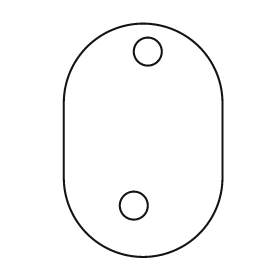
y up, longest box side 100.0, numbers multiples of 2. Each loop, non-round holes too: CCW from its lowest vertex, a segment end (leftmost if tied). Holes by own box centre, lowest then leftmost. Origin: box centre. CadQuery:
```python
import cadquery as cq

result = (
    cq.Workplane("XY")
    .moveTo(-34.0, -16.0)
    .threePointArc((0.0, -50.0), (34.0, -16.0))
    .lineTo(34.0, 16.0)
    .threePointArc((0.0, 50.0), (-34.0, 16.0))
    .close()
    .moveTo(-4.0, -28.0)
    .circle(6.0)
    .moveTo(2.0, 38.0)
    .circle(6.0)
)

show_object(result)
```